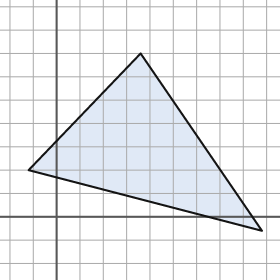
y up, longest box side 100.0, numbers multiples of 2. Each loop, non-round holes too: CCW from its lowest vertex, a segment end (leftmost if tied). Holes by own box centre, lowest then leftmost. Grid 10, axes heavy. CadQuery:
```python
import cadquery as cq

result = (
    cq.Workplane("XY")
    .moveTo(88.0, -6.0)
    .lineTo(36.0, 70.0)
    .lineTo(-12.0, 20.0)
    .close()
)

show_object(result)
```